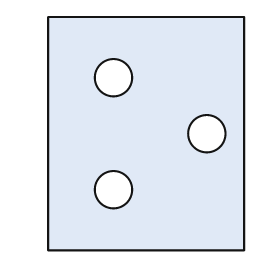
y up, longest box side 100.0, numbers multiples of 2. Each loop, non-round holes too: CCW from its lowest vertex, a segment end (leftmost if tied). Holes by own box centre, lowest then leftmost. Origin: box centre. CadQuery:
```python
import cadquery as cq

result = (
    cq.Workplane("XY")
    .moveTo(-42.0, -50.0)
    .lineTo(42.0, -50.0)
    .lineTo(42.0, 50.0)
    .lineTo(-42.0, 50.0)
    .close()
    .moveTo(-14.0, -24.0)
    .circle(8.0)
    .moveTo(26.0, 0.0)
    .circle(8.0)
    .moveTo(-14.0, 24.0)
    .circle(8.0)
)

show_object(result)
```